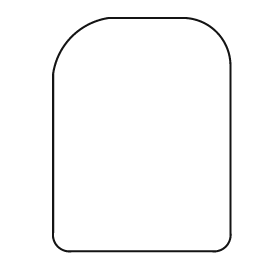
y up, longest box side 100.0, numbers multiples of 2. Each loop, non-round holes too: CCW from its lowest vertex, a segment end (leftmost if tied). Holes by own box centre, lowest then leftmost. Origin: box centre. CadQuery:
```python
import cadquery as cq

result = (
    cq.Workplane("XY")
    .moveTo(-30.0, -50.0)
    .lineTo(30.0, -50.0)
    .threePointArc((36.0, -48.0), (38.0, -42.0))
    .lineTo(38.0, 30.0)
    .threePointArc((32.0, 44.0), (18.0, 50.0))
    .lineTo(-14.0, 50.0)
    .threePointArc((-30.0, 42.0), (-38.0, 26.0))
    .lineTo(-38.0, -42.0)
    .threePointArc((-36.0, -48.0), (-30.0, -50.0))
    .close()
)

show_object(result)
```